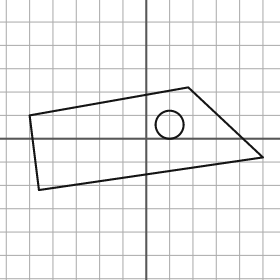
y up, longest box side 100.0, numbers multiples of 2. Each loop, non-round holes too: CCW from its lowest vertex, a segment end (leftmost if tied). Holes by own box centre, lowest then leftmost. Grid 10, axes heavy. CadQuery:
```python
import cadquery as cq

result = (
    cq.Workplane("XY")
    .moveTo(-46.0, -22.0)
    .lineTo(50.0, -8.0)
    .lineTo(18.0, 22.0)
    .lineTo(-50.0, 10.0)
    .close()
    .moveTo(10.0, 6.0)
    .circle(6.0)
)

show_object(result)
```